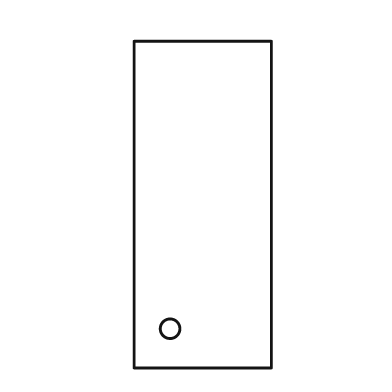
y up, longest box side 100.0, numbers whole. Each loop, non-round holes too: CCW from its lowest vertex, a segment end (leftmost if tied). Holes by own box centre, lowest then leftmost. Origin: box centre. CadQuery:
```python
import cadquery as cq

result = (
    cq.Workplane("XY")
    .moveTo(-21.0, -50.0)
    .lineTo(21.0, -50.0)
    .lineTo(21.0, 50.0)
    .lineTo(-21.0, 50.0)
    .close()
    .moveTo(-10.0, -38.0)
    .circle(3.0)
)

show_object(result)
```